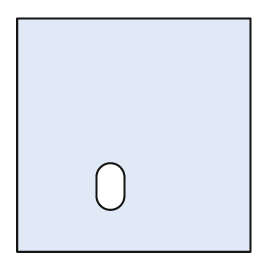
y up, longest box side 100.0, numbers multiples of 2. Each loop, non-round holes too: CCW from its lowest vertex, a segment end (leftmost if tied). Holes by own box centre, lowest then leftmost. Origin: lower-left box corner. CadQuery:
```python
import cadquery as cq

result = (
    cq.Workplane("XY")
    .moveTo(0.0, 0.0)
    .lineTo(100.0, 0.0)
    .lineTo(100.0, 100.0)
    .lineTo(0.0, 100.0)
    .close()
    .moveTo(34.0, 24.0)
    .threePointArc((40.0, 18.0), (46.0, 24.0))
    .lineTo(46.0, 32.0)
    .threePointArc((40.0, 38.0), (34.0, 32.0))
    .close()
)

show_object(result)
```